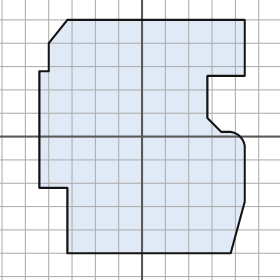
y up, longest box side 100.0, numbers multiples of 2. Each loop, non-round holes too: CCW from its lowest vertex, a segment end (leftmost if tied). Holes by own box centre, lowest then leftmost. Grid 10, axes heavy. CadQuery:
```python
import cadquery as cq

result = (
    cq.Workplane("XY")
    .moveTo(-32.0, -50.0)
    .lineTo(38.0, -50.0)
    .lineTo(44.0, -28.0)
    .lineTo(44.0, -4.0)
    .threePointArc((42.0, 0.0), (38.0, 2.0))
    .lineTo(34.0, 2.0)
    .lineTo(28.0, 8.0)
    .lineTo(28.0, 26.0)
    .lineTo(44.0, 26.0)
    .lineTo(44.0, 50.0)
    .lineTo(-32.0, 50.0)
    .lineTo(-40.0, 40.0)
    .lineTo(-40.0, 28.0)
    .lineTo(-44.0, 28.0)
    .lineTo(-44.0, -22.0)
    .lineTo(-32.0, -22.0)
    .close()
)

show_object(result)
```